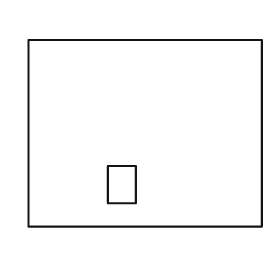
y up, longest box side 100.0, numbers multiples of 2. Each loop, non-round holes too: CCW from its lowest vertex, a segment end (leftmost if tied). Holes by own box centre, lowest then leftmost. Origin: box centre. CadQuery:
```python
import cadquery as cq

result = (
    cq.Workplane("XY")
    .moveTo(-50.0, -40.0)
    .lineTo(50.0, -40.0)
    .lineTo(50.0, 40.0)
    .lineTo(-50.0, 40.0)
    .close()
    .moveTo(-16.0, -30.0)
    .lineTo(-4.0, -30.0)
    .lineTo(-4.0, -14.0)
    .lineTo(-16.0, -14.0)
    .close()
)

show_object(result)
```